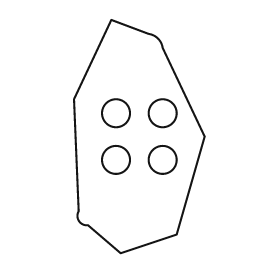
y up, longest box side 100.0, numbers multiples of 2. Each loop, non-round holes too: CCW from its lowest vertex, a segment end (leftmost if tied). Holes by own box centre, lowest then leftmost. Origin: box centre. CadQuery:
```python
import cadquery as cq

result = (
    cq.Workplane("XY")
    .moveTo(-8.0, -50.0)
    .lineTo(16.0, -42.0)
    .lineTo(28.0, 0.0)
    .lineTo(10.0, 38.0)
    .threePointArc((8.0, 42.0), (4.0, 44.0))
    .lineTo(-12.0, 50.0)
    .lineTo(-28.0, 16.0)
    .lineTo(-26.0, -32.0)
    .threePointArc((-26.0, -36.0), (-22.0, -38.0))
    .close()
    .moveTo(-10.0, -10.0)
    .circle(6.0)
    .moveTo(10.0, -10.0)
    .circle(6.0)
    .moveTo(-10.0, 10.0)
    .circle(6.0)
    .moveTo(10.0, 10.0)
    .circle(6.0)
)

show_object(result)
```